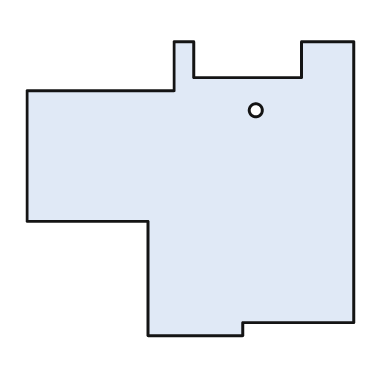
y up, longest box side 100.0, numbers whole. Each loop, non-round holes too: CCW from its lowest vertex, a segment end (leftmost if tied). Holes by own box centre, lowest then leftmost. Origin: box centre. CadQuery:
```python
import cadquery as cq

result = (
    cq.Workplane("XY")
    .moveTo(-13.0, -45.0)
    .lineTo(16.0, -45.0)
    .lineTo(16.0, -41.0)
    .lineTo(50.0, -41.0)
    .lineTo(50.0, 45.0)
    .lineTo(34.0, 45.0)
    .lineTo(34.0, 34.0)
    .lineTo(1.0, 34.0)
    .lineTo(1.0, 45.0)
    .lineTo(-5.0, 45.0)
    .lineTo(-5.0, 30.0)
    .lineTo(-50.0, 30.0)
    .lineTo(-50.0, -10.0)
    .lineTo(-13.0, -10.0)
    .close()
    .moveTo(20.0, 24.0)
    .circle(2.0)
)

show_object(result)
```